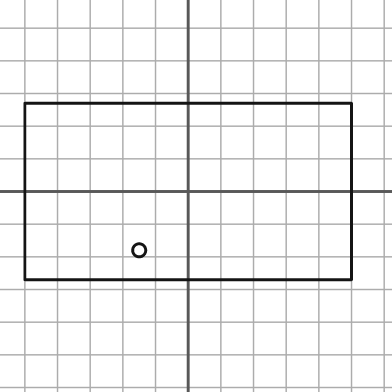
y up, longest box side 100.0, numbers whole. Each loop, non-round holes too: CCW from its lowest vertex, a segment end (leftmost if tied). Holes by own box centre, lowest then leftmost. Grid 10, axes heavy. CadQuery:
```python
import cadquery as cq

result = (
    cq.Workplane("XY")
    .moveTo(-50.0, -27.0)
    .lineTo(50.0, -27.0)
    .lineTo(50.0, 27.0)
    .lineTo(-50.0, 27.0)
    .close()
    .moveTo(-15.0, -18.0)
    .circle(2.0)
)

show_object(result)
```